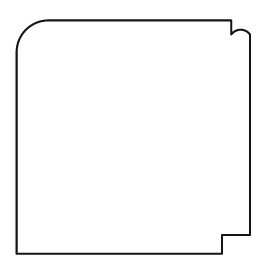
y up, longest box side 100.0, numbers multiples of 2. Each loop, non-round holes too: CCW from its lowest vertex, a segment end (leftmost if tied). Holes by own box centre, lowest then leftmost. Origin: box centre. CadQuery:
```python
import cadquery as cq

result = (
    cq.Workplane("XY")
    .moveTo(-50.0, -50.0)
    .lineTo(38.0, -50.0)
    .lineTo(38.0, -42.0)
    .lineTo(50.0, -42.0)
    .lineTo(50.0, 44.0)
    .threePointArc((46.0, 46.0), (42.0, 44.0))
    .lineTo(42.0, 50.0)
    .lineTo(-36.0, 50.0)
    .threePointArc((-46.0, 46.0), (-50.0, 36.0))
    .close()
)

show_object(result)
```